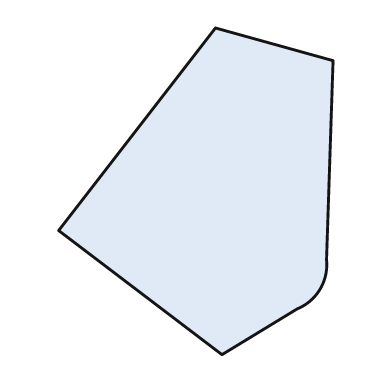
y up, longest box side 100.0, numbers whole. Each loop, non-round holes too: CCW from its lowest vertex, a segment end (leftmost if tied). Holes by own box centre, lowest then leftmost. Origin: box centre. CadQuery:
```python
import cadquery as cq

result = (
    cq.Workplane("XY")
    .moveTo(8.0, -50.0)
    .lineTo(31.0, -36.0)
    .threePointArc((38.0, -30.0), (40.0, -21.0))
    .lineTo(42.0, 40.0)
    .lineTo(6.0, 50.0)
    .lineTo(-42.0, -12.0)
    .close()
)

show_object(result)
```